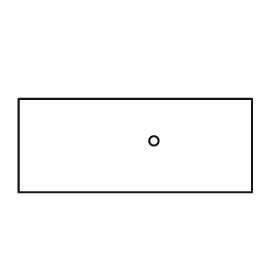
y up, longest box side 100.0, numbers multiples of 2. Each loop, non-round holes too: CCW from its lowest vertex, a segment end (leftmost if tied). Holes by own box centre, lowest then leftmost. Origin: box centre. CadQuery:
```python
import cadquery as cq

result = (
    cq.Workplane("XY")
    .moveTo(-50.0, -20.0)
    .lineTo(50.0, -20.0)
    .lineTo(50.0, 20.0)
    .lineTo(-50.0, 20.0)
    .close()
    .moveTo(8.0, 2.0)
    .circle(2.0)
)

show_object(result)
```